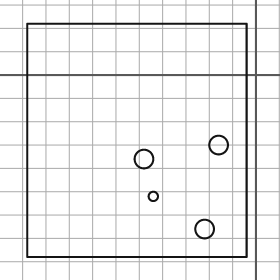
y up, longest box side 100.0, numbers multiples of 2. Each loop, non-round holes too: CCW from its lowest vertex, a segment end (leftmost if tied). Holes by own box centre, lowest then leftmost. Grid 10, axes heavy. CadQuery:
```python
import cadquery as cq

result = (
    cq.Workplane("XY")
    .moveTo(-98.0, -78.0)
    .lineTo(-4.0, -78.0)
    .lineTo(-4.0, 22.0)
    .lineTo(-98.0, 22.0)
    .close()
    .moveTo(-22.0, -66.0)
    .circle(4.0)
    .moveTo(-44.0, -52.0)
    .circle(2.0)
    .moveTo(-48.0, -36.0)
    .circle(4.0)
    .moveTo(-16.0, -30.0)
    .circle(4.0)
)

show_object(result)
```